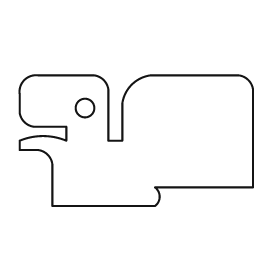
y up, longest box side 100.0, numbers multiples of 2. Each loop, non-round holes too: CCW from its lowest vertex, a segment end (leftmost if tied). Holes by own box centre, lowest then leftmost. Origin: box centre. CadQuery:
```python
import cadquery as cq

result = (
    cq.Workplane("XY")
    .moveTo(-36.0, -28.0)
    .lineTo(8.0, -28.0)
    .threePointArc((10.0, -24.0), (8.0, -20.0))
    .lineTo(50.0, -20.0)
    .lineTo(50.0, 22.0)
    .threePointArc((48.0, 26.0), (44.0, 28.0))
    .lineTo(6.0, 28.0)
    .threePointArc((-2.0, 24.0), (-6.0, 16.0))
    .lineTo(-6.0, 0.0)
    .lineTo(-12.0, 0.0)
    .lineTo(-12.0, 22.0)
    .threePointArc((-14.0, 26.0), (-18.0, 28.0))
    .lineTo(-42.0, 28.0)
    .threePointArc((-48.0, 26.0), (-50.0, 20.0))
    .lineTo(-50.0, 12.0)
    .threePointArc((-48.0, 8.0), (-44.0, 6.0))
    .lineTo(-30.0, 6.0)
    .lineTo(-30.0, 0.0)
    .threePointArc((-40.0, 2.0), (-50.0, 0.0))
    .lineTo(-50.0, -4.0)
    .lineTo(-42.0, -4.0)
    .threePointArc((-38.0, -6.0), (-36.0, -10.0))
    .close()
    .moveTo(-22.0, 14.0)
    .circle(4.0)
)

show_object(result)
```